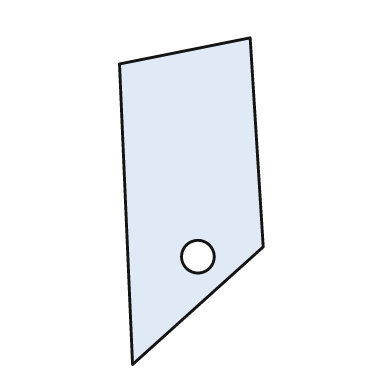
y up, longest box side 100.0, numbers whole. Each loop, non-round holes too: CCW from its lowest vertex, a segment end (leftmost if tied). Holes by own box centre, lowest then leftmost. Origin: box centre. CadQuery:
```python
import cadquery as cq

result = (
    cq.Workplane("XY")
    .moveTo(-18.0, -50.0)
    .lineTo(22.0, -14.0)
    .lineTo(18.0, 50.0)
    .lineTo(-22.0, 42.0)
    .close()
    .moveTo(2.0, -17.0)
    .circle(5.0)
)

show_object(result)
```